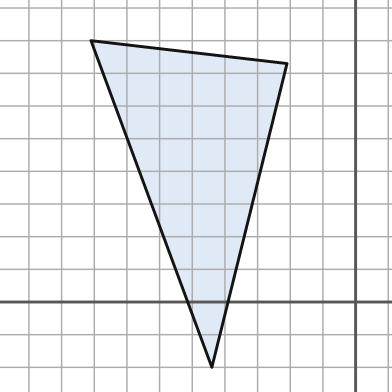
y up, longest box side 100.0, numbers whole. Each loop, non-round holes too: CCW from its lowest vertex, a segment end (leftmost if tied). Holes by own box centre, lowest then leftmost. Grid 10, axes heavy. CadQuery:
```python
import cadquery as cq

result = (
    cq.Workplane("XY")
    .moveTo(-44.0, -20.0)
    .lineTo(-21.0, 73.0)
    .lineTo(-81.0, 80.0)
    .close()
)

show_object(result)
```